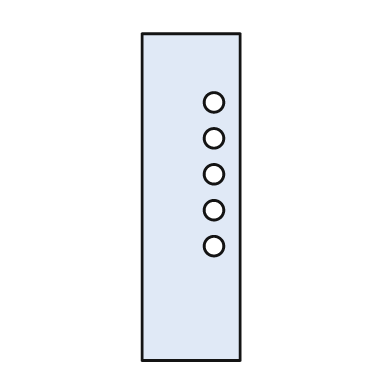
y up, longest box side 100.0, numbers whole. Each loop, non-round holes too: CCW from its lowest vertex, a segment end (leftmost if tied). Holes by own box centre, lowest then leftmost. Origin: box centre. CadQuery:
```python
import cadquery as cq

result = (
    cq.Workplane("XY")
    .moveTo(-15.0, -50.0)
    .lineTo(15.0, -50.0)
    .lineTo(15.0, 50.0)
    .lineTo(-15.0, 50.0)
    .close()
    .moveTo(7.0, -15.0)
    .circle(3.0)
    .moveTo(7.0, -4.0)
    .circle(3.0)
    .moveTo(7.0, 7.0)
    .circle(3.0)
    .moveTo(7.0, 18.0)
    .circle(3.0)
    .moveTo(7.0, 29.0)
    .circle(3.0)
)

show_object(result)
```